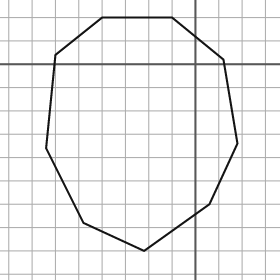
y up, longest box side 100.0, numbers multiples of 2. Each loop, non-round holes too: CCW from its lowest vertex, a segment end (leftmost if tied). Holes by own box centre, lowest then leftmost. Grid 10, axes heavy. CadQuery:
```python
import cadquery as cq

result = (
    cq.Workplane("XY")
    .moveTo(-22.0, -80.0)
    .lineTo(6.0, -60.0)
    .lineTo(18.0, -34.0)
    .lineTo(12.0, 2.0)
    .lineTo(-10.0, 20.0)
    .lineTo(-40.0, 20.0)
    .lineTo(-60.0, 4.0)
    .lineTo(-64.0, -36.0)
    .lineTo(-48.0, -68.0)
    .close()
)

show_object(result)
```